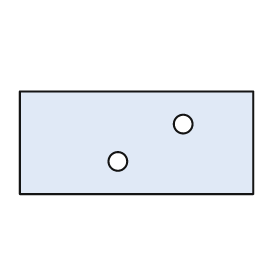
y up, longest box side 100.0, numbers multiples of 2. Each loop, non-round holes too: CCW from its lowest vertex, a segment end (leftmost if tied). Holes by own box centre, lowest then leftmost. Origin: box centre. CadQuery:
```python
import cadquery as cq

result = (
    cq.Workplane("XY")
    .moveTo(-50.0, -22.0)
    .lineTo(50.0, -22.0)
    .lineTo(50.0, 22.0)
    .lineTo(-50.0, 22.0)
    .close()
    .moveTo(-8.0, -8.0)
    .circle(4.0)
    .moveTo(20.0, 8.0)
    .circle(4.0)
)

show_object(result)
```